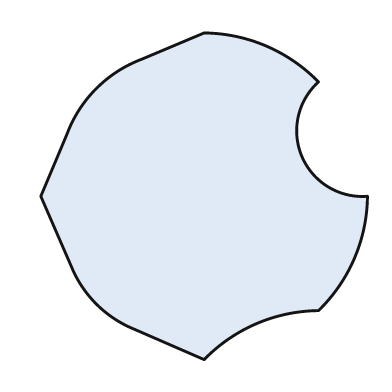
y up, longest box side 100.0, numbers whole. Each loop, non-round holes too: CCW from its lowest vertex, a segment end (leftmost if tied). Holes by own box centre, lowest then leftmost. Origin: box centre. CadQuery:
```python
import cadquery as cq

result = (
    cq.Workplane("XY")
    .moveTo(0.0, -50.0)
    .threePointArc((16.0, -39.0), (35.0, -35.0))
    .threePointArc((46.0, -19.0), (50.0, 0.0))
    .threePointArc((30.0, 12.0), (35.0, 35.0))
    .threePointArc((19.0, 46.0), (0.0, 50.0))
    .lineTo(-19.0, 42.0)
    .threePointArc((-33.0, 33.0), (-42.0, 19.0))
    .lineTo(-50.0, 0.0)
    .lineTo(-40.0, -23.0)
    .threePointArc((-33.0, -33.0), (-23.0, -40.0))
    .close()
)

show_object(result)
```